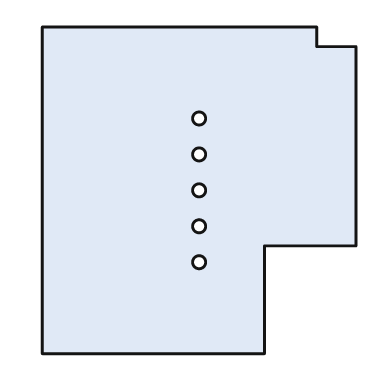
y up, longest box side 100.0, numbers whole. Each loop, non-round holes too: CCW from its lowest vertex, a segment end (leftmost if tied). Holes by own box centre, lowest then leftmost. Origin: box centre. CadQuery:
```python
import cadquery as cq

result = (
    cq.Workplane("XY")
    .moveTo(-48.0, -50.0)
    .lineTo(20.0, -50.0)
    .lineTo(20.0, -17.0)
    .lineTo(48.0, -17.0)
    .lineTo(48.0, 44.0)
    .lineTo(36.0, 44.0)
    .lineTo(36.0, 50.0)
    .lineTo(-48.0, 50.0)
    .close()
    .moveTo(0.0, -22.0)
    .circle(2.0)
    .moveTo(0.0, -11.0)
    .circle(2.0)
    .moveTo(0.0, 0.0)
    .circle(2.0)
    .moveTo(0.0, 11.0)
    .circle(2.0)
    .moveTo(0.0, 22.0)
    .circle(2.0)
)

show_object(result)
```